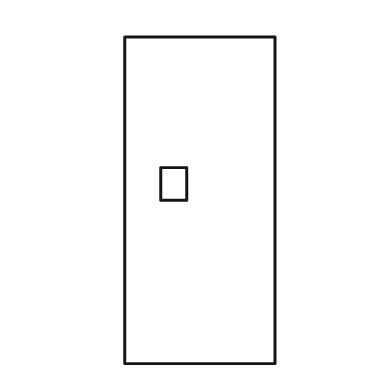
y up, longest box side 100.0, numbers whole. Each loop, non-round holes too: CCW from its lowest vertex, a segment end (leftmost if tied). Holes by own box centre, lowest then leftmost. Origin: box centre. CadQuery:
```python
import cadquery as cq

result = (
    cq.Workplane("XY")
    .moveTo(-23.0, -50.0)
    .lineTo(23.0, -50.0)
    .lineTo(23.0, 50.0)
    .lineTo(-23.0, 50.0)
    .close()
    .moveTo(-12.0, 0.0)
    .lineTo(-4.0, 0.0)
    .lineTo(-4.0, 10.0)
    .lineTo(-12.0, 10.0)
    .close()
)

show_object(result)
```